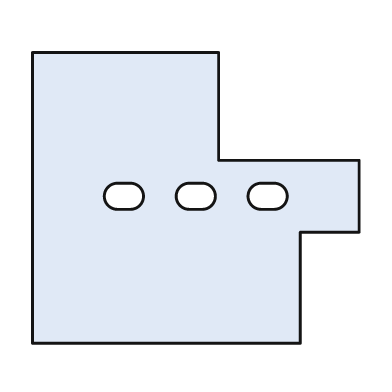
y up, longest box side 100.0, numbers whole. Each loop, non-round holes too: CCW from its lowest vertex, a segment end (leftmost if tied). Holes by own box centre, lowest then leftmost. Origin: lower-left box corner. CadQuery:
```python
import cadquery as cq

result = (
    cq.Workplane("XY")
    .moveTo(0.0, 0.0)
    .lineTo(82.0, 0.0)
    .lineTo(82.0, 34.0)
    .lineTo(100.0, 34.0)
    .lineTo(100.0, 56.0)
    .lineTo(57.0, 56.0)
    .lineTo(57.0, 89.0)
    .lineTo(0.0, 89.0)
    .close()
    .moveTo(26.0, 41.0)
    .lineTo(30.0, 41.0)
    .threePointArc((34.0, 45.0), (30.0, 49.0))
    .lineTo(26.0, 49.0)
    .threePointArc((22.0, 45.0), (26.0, 41.0))
    .close()
    .moveTo(48.0, 41.0)
    .lineTo(52.0, 41.0)
    .threePointArc((56.0, 45.0), (52.0, 49.0))
    .lineTo(48.0, 49.0)
    .threePointArc((44.0, 45.0), (48.0, 41.0))
    .close()
    .moveTo(70.0, 41.0)
    .lineTo(74.0, 41.0)
    .threePointArc((78.0, 45.0), (74.0, 49.0))
    .lineTo(70.0, 49.0)
    .threePointArc((66.0, 45.0), (70.0, 41.0))
    .close()
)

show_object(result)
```